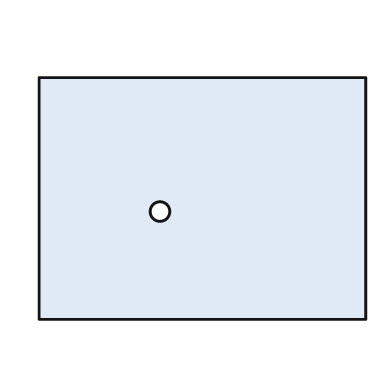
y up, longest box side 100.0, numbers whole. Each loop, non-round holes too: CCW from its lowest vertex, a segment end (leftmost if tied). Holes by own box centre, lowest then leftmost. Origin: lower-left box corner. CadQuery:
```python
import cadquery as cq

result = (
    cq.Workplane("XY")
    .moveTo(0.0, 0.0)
    .lineTo(100.0, 0.0)
    .lineTo(100.0, 74.0)
    .lineTo(0.0, 74.0)
    .close()
    .moveTo(37.0, 33.0)
    .circle(3.0)
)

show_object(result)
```